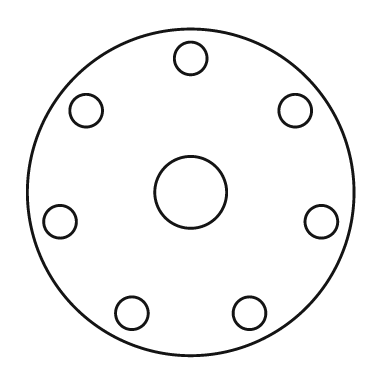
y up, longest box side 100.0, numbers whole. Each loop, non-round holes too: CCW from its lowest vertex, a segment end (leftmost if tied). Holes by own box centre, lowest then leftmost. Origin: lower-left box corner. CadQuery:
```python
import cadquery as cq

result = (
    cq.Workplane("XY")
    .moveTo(50.0, 50.0)
    .circle(50.0)
    .moveTo(32.0, 13.0)
    .circle(5.0)
    .moveTo(68.0, 13.0)
    .circle(5.0)
    .moveTo(10.0, 41.0)
    .circle(5.0)
    .moveTo(90.0, 41.0)
    .circle(5.0)
    .moveTo(50.0, 50.0)
    .circle(11.0)
    .moveTo(18.0, 75.0)
    .circle(5.0)
    .moveTo(82.0, 75.0)
    .circle(5.0)
    .moveTo(50.0, 91.0)
    .circle(5.0)
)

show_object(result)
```